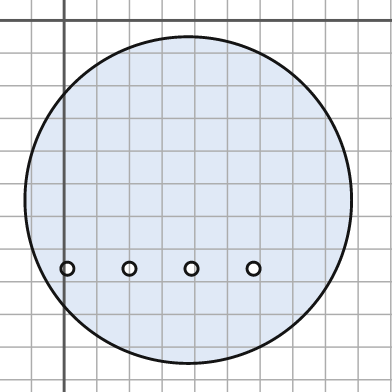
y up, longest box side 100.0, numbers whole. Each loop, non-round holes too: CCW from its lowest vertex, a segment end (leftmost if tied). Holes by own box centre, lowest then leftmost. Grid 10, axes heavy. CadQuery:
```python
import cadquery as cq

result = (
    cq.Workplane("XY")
    .moveTo(38.0, -55.0)
    .circle(50.0)
    .moveTo(1.0, -76.0)
    .circle(2.0)
    .moveTo(20.0, -76.0)
    .circle(2.0)
    .moveTo(39.0, -76.0)
    .circle(2.0)
    .moveTo(58.0, -76.0)
    .circle(2.0)
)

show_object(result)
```